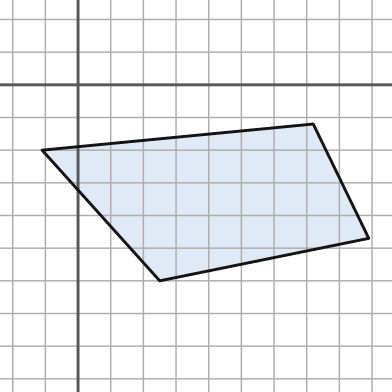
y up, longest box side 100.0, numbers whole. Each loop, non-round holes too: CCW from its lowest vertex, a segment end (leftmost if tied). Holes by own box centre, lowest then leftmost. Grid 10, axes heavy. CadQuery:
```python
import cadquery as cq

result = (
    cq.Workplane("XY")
    .moveTo(25.0, -60.0)
    .lineTo(89.0, -47.0)
    .lineTo(72.0, -12.0)
    .lineTo(-11.0, -20.0)
    .close()
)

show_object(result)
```